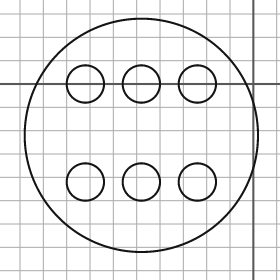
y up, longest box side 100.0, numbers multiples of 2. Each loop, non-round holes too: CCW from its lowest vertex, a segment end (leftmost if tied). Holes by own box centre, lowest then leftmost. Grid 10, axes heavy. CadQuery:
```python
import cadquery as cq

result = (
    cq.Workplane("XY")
    .moveTo(-48.0, -22.0)
    .circle(50.0)
    .moveTo(-72.0, -42.0)
    .circle(8.0)
    .moveTo(-48.0, -42.0)
    .circle(8.0)
    .moveTo(-24.0, -42.0)
    .circle(8.0)
    .moveTo(-72.0, 0.0)
    .circle(8.0)
    .moveTo(-48.0, 0.0)
    .circle(8.0)
    .moveTo(-24.0, 0.0)
    .circle(8.0)
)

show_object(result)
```